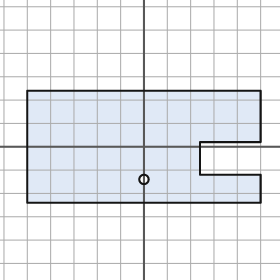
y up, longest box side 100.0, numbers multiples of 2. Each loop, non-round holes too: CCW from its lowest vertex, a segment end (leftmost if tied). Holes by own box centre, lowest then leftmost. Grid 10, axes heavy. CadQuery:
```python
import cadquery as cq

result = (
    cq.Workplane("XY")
    .moveTo(-50.0, -24.0)
    .lineTo(50.0, -24.0)
    .lineTo(50.0, -12.0)
    .lineTo(24.0, -12.0)
    .lineTo(24.0, 2.0)
    .lineTo(50.0, 2.0)
    .lineTo(50.0, 24.0)
    .lineTo(-50.0, 24.0)
    .close()
    .moveTo(0.0, -14.0)
    .circle(2.0)
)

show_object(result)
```